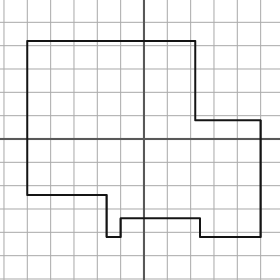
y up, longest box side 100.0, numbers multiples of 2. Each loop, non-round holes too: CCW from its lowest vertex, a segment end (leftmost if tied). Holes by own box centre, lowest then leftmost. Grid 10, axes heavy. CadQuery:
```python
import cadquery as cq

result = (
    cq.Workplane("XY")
    .moveTo(-16.0, -42.0)
    .lineTo(-10.0, -42.0)
    .lineTo(-10.0, -34.0)
    .lineTo(24.0, -34.0)
    .lineTo(24.0, -42.0)
    .lineTo(50.0, -42.0)
    .lineTo(50.0, 8.0)
    .lineTo(22.0, 8.0)
    .lineTo(22.0, 42.0)
    .lineTo(-50.0, 42.0)
    .lineTo(-50.0, -24.0)
    .lineTo(-16.0, -24.0)
    .close()
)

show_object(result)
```